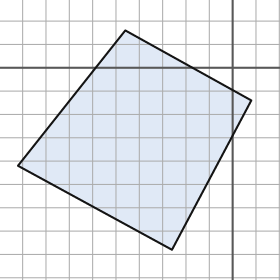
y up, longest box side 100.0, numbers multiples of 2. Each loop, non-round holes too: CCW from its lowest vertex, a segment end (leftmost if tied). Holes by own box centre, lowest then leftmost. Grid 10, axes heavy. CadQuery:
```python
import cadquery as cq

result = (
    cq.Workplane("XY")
    .moveTo(-26.0, -78.0)
    .lineTo(8.0, -14.0)
    .lineTo(-46.0, 16.0)
    .lineTo(-92.0, -42.0)
    .close()
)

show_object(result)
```